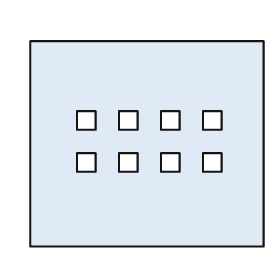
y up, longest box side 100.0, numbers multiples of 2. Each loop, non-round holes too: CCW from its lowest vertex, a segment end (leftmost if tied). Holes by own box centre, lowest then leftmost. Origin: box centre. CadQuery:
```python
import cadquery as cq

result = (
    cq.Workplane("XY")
    .moveTo(-50.0, -44.0)
    .lineTo(50.0, -44.0)
    .lineTo(50.0, 44.0)
    .lineTo(-50.0, 44.0)
    .close()
    .moveTo(-30.0, -12.0)
    .lineTo(-22.0, -12.0)
    .lineTo(-22.0, -4.0)
    .lineTo(-30.0, -4.0)
    .close()
    .moveTo(-12.0, -12.0)
    .lineTo(-4.0, -12.0)
    .lineTo(-4.0, -4.0)
    .lineTo(-12.0, -4.0)
    .close()
    .moveTo(6.0, -12.0)
    .lineTo(14.0, -12.0)
    .lineTo(14.0, -4.0)
    .lineTo(6.0, -4.0)
    .close()
    .moveTo(24.0, -12.0)
    .lineTo(32.0, -12.0)
    .lineTo(32.0, -4.0)
    .lineTo(24.0, -4.0)
    .close()
    .moveTo(-30.0, 6.0)
    .lineTo(-22.0, 6.0)
    .lineTo(-22.0, 14.0)
    .lineTo(-30.0, 14.0)
    .close()
    .moveTo(-12.0, 6.0)
    .lineTo(-4.0, 6.0)
    .lineTo(-4.0, 14.0)
    .lineTo(-12.0, 14.0)
    .close()
    .moveTo(6.0, 6.0)
    .lineTo(14.0, 6.0)
    .lineTo(14.0, 14.0)
    .lineTo(6.0, 14.0)
    .close()
    .moveTo(24.0, 6.0)
    .lineTo(32.0, 6.0)
    .lineTo(32.0, 14.0)
    .lineTo(24.0, 14.0)
    .close()
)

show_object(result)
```